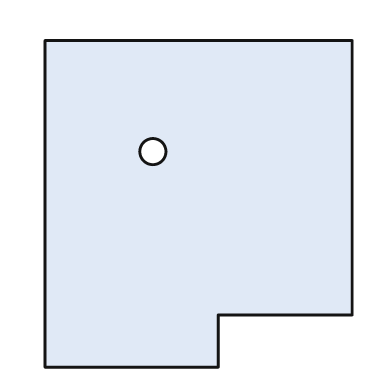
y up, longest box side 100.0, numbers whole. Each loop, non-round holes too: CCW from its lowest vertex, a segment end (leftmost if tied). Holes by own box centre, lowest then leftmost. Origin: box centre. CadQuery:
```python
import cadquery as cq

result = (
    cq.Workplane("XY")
    .moveTo(-47.0, -50.0)
    .lineTo(6.0, -50.0)
    .lineTo(6.0, -34.0)
    .lineTo(47.0, -34.0)
    .lineTo(47.0, 50.0)
    .lineTo(-47.0, 50.0)
    .close()
    .moveTo(-14.0, 16.0)
    .circle(4.0)
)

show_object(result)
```